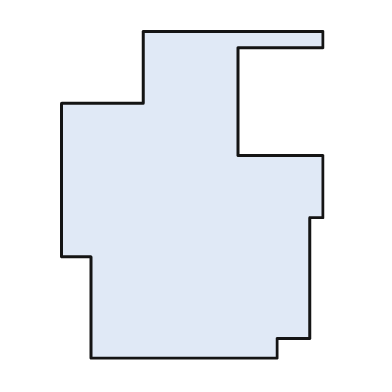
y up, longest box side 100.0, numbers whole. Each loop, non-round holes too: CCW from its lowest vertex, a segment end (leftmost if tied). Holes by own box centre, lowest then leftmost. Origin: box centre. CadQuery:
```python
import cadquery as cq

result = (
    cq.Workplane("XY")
    .moveTo(-31.0, -50.0)
    .lineTo(26.0, -50.0)
    .lineTo(26.0, -44.0)
    .lineTo(36.0, -44.0)
    .lineTo(36.0, -7.0)
    .lineTo(40.0, -7.0)
    .lineTo(40.0, 12.0)
    .lineTo(14.0, 12.0)
    .lineTo(14.0, 45.0)
    .lineTo(40.0, 45.0)
    .lineTo(40.0, 50.0)
    .lineTo(-15.0, 50.0)
    .lineTo(-15.0, 28.0)
    .lineTo(-40.0, 28.0)
    .lineTo(-40.0, -19.0)
    .lineTo(-31.0, -19.0)
    .close()
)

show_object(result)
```